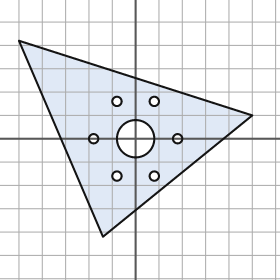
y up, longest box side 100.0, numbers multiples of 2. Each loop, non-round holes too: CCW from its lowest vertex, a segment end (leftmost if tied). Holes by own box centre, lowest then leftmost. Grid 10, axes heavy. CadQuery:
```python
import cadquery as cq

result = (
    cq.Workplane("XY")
    .moveTo(-14.0, -42.0)
    .lineTo(50.0, 10.0)
    .lineTo(-50.0, 42.0)
    .close()
    .moveTo(-8.0, -16.0)
    .circle(2.0)
    .moveTo(8.0, -16.0)
    .circle(2.0)
    .moveTo(-18.0, 0.0)
    .circle(2.0)
    .moveTo(0.0, 0.0)
    .circle(8.0)
    .moveTo(18.0, 0.0)
    .circle(2.0)
    .moveTo(-8.0, 16.0)
    .circle(2.0)
    .moveTo(8.0, 16.0)
    .circle(2.0)
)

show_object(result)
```